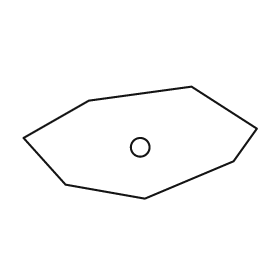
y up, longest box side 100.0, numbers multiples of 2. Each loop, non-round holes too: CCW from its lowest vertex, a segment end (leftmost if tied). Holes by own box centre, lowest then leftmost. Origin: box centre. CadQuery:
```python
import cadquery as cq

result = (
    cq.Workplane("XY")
    .moveTo(2.0, -24.0)
    .lineTo(40.0, -8.0)
    .lineTo(50.0, 6.0)
    .lineTo(22.0, 24.0)
    .lineTo(-22.0, 18.0)
    .lineTo(-50.0, 2.0)
    .lineTo(-32.0, -18.0)
    .close()
    .moveTo(0.0, -2.0)
    .circle(4.0)
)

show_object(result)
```